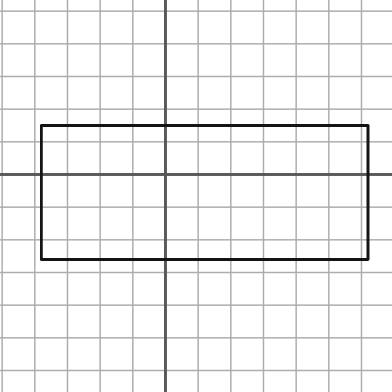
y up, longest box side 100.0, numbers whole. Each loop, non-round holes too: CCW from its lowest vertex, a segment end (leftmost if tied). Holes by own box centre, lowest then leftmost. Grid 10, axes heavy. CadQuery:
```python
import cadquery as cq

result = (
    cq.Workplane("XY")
    .moveTo(-38.0, -26.0)
    .lineTo(62.0, -26.0)
    .lineTo(62.0, 15.0)
    .lineTo(-38.0, 15.0)
    .close()
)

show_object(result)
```